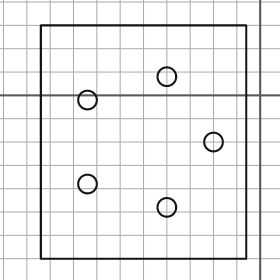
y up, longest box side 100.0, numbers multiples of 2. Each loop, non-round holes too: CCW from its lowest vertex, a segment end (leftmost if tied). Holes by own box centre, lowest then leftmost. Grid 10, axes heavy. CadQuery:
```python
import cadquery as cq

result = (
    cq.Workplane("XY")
    .moveTo(-94.0, -70.0)
    .lineTo(-6.0, -70.0)
    .lineTo(-6.0, 30.0)
    .lineTo(-94.0, 30.0)
    .close()
    .moveTo(-40.0, -48.0)
    .circle(4.0)
    .moveTo(-74.0, -38.0)
    .circle(4.0)
    .moveTo(-20.0, -20.0)
    .circle(4.0)
    .moveTo(-74.0, -2.0)
    .circle(4.0)
    .moveTo(-40.0, 8.0)
    .circle(4.0)
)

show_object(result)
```